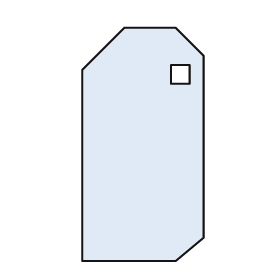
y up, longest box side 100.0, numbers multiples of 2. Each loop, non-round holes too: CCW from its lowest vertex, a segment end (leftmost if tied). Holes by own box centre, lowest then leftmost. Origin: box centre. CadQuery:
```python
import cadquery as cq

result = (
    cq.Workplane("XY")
    .moveTo(-26.0, -50.0)
    .lineTo(14.0, -50.0)
    .lineTo(26.0, -40.0)
    .lineTo(26.0, 38.0)
    .lineTo(14.0, 50.0)
    .lineTo(-8.0, 50.0)
    .lineTo(-26.0, 32.0)
    .close()
    .moveTo(12.0, 26.0)
    .lineTo(20.0, 26.0)
    .lineTo(20.0, 34.0)
    .lineTo(12.0, 34.0)
    .close()
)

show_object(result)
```